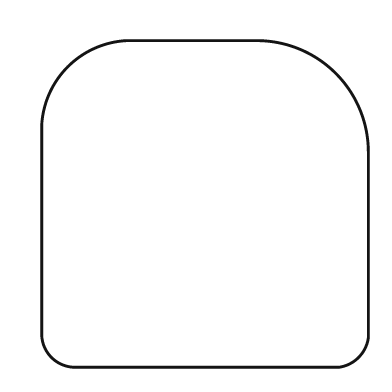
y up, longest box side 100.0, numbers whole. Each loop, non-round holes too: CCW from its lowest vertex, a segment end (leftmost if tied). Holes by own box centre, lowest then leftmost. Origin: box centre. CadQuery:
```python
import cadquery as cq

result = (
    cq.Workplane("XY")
    .moveTo(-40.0, -50.0)
    .lineTo(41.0, -50.0)
    .threePointArc((47.0, -47.0), (50.0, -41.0))
    .lineTo(50.0, 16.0)
    .threePointArc((40.0, 40.0), (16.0, 50.0))
    .lineTo(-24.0, 50.0)
    .threePointArc((-42.0, 42.0), (-50.0, 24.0))
    .lineTo(-50.0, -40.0)
    .threePointArc((-47.0, -47.0), (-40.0, -50.0))
    .close()
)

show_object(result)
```